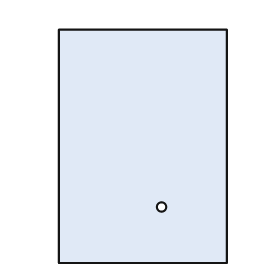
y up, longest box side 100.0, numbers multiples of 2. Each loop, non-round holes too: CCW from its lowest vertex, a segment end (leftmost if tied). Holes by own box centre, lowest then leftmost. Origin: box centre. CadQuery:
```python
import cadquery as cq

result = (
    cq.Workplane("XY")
    .moveTo(-36.0, -50.0)
    .lineTo(36.0, -50.0)
    .lineTo(36.0, 50.0)
    .lineTo(-36.0, 50.0)
    .close()
    .moveTo(8.0, -26.0)
    .circle(2.0)
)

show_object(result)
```